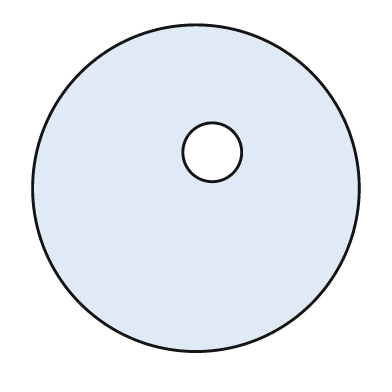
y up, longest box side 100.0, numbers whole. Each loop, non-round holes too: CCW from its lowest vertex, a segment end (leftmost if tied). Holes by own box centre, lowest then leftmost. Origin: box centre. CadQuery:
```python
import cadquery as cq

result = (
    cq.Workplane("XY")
    .moveTo(0.0, 0.0)
    .circle(50.0)
    .moveTo(5.0, 11.0)
    .circle(9.0)
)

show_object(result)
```